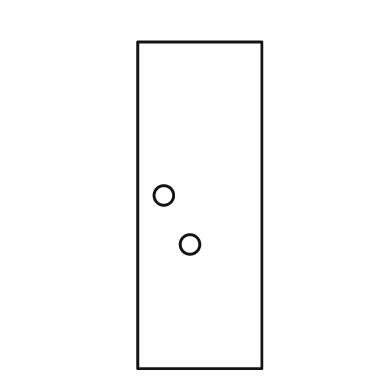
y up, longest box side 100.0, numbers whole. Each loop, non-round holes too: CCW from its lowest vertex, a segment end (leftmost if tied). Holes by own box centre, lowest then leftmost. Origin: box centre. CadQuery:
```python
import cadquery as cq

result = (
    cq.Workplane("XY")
    .moveTo(-19.0, -50.0)
    .lineTo(19.0, -50.0)
    .lineTo(19.0, 50.0)
    .lineTo(-19.0, 50.0)
    .close()
    .moveTo(-3.0, -12.0)
    .circle(3.0)
    .moveTo(-11.0, 3.0)
    .circle(3.0)
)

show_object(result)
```